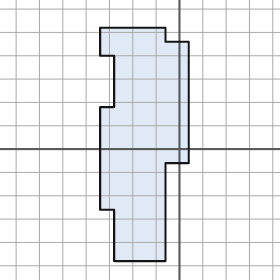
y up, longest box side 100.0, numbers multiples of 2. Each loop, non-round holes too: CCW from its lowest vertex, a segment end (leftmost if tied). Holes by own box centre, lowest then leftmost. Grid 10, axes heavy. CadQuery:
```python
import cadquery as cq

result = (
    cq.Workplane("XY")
    .moveTo(-28.0, -48.0)
    .lineTo(-6.0, -48.0)
    .lineTo(-6.0, -6.0)
    .lineTo(4.0, -6.0)
    .lineTo(4.0, 46.0)
    .lineTo(-6.0, 46.0)
    .lineTo(-6.0, 52.0)
    .lineTo(-34.0, 52.0)
    .lineTo(-34.0, 40.0)
    .lineTo(-28.0, 40.0)
    .lineTo(-28.0, 18.0)
    .lineTo(-34.0, 18.0)
    .lineTo(-34.0, -26.0)
    .lineTo(-28.0, -26.0)
    .close()
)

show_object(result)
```